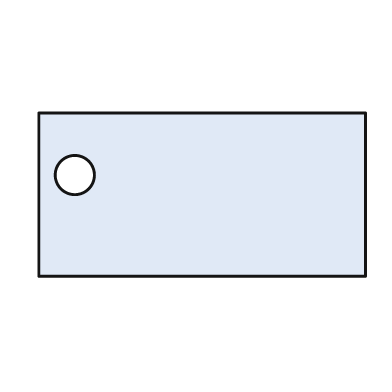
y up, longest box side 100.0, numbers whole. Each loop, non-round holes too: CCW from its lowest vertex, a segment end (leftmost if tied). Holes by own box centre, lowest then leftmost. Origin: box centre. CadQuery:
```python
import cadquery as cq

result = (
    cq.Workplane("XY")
    .moveTo(-50.0, -25.0)
    .lineTo(50.0, -25.0)
    .lineTo(50.0, 25.0)
    .lineTo(-50.0, 25.0)
    .close()
    .moveTo(-39.0, 6.0)
    .circle(6.0)
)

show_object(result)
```